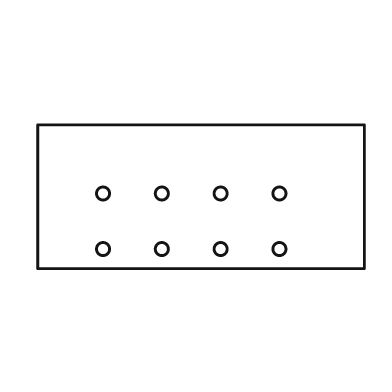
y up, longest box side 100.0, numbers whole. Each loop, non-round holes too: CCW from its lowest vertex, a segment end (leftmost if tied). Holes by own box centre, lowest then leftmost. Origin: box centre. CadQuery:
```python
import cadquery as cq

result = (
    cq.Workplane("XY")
    .moveTo(-50.0, -22.0)
    .lineTo(50.0, -22.0)
    .lineTo(50.0, 22.0)
    .lineTo(-50.0, 22.0)
    .close()
    .moveTo(-30.0, -16.0)
    .circle(2.0)
    .moveTo(-12.0, -16.0)
    .circle(2.0)
    .moveTo(6.0, -16.0)
    .circle(2.0)
    .moveTo(24.0, -16.0)
    .circle(2.0)
    .moveTo(-30.0, 1.0)
    .circle(2.0)
    .moveTo(-12.0, 1.0)
    .circle(2.0)
    .moveTo(6.0, 1.0)
    .circle(2.0)
    .moveTo(24.0, 1.0)
    .circle(2.0)
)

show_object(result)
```